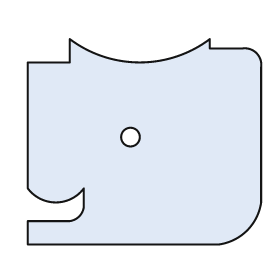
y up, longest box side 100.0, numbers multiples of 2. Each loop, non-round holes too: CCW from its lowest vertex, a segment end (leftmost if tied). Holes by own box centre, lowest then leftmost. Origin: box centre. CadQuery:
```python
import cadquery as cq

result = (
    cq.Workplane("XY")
    .moveTo(-50.0, -44.0)
    .lineTo(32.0, -44.0)
    .threePointArc((44.0, -38.0), (50.0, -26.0))
    .lineTo(50.0, 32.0)
    .threePointArc((48.0, 38.0), (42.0, 40.0))
    .lineTo(28.0, 40.0)
    .lineTo(28.0, 44.0)
    .threePointArc((-2.0, 34.0), (-32.0, 44.0))
    .lineTo(-32.0, 34.0)
    .lineTo(-50.0, 34.0)
    .lineTo(-50.0, -20.0)
    .threePointArc((-38.0, -26.0), (-26.0, -20.0))
    .lineTo(-26.0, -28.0)
    .threePointArc((-28.0, -32.0), (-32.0, -34.0))
    .lineTo(-50.0, -34.0)
    .close()
    .moveTo(-6.0, 2.0)
    .circle(4.0)
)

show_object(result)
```